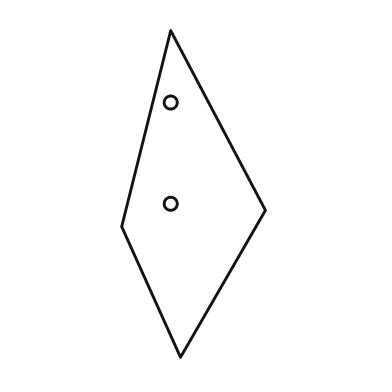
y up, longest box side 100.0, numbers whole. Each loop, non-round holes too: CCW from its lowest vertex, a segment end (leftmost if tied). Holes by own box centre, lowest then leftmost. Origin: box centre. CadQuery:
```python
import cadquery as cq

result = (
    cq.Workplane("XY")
    .moveTo(-4.0, -50.0)
    .lineTo(22.0, -5.0)
    .lineTo(-7.0, 50.0)
    .lineTo(-22.0, -10.0)
    .close()
    .moveTo(-7.0, -3.0)
    .circle(2.0)
    .moveTo(-7.0, 28.0)
    .circle(2.0)
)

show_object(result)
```